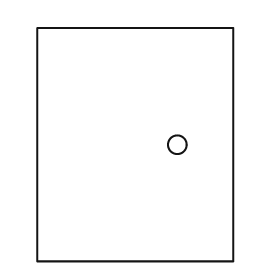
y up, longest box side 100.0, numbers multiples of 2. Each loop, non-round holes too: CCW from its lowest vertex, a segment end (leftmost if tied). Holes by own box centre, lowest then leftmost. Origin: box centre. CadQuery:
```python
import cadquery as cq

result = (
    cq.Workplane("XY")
    .moveTo(-42.0, -50.0)
    .lineTo(42.0, -50.0)
    .lineTo(42.0, 50.0)
    .lineTo(-42.0, 50.0)
    .close()
    .moveTo(18.0, 0.0)
    .circle(4.0)
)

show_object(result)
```